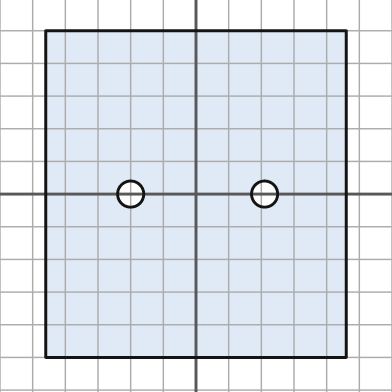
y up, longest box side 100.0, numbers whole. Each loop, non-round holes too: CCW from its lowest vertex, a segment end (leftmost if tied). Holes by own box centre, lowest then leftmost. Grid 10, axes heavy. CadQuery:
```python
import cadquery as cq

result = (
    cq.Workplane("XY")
    .moveTo(-46.0, -50.0)
    .lineTo(46.0, -50.0)
    .lineTo(46.0, 50.0)
    .lineTo(-46.0, 50.0)
    .close()
    .moveTo(-20.0, 0.0)
    .circle(4.0)
    .moveTo(21.0, 0.0)
    .circle(4.0)
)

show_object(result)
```